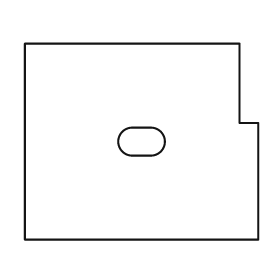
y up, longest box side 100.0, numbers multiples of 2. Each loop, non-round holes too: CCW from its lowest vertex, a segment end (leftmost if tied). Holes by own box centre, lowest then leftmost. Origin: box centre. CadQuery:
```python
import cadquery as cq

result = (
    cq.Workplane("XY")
    .moveTo(-50.0, -42.0)
    .lineTo(50.0, -42.0)
    .lineTo(50.0, 8.0)
    .lineTo(42.0, 8.0)
    .lineTo(42.0, 42.0)
    .lineTo(-50.0, 42.0)
    .close()
    .moveTo(-4.0, -6.0)
    .lineTo(4.0, -6.0)
    .threePointArc((10.0, 0.0), (4.0, 6.0))
    .lineTo(-4.0, 6.0)
    .threePointArc((-10.0, 0.0), (-4.0, -6.0))
    .close()
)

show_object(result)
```